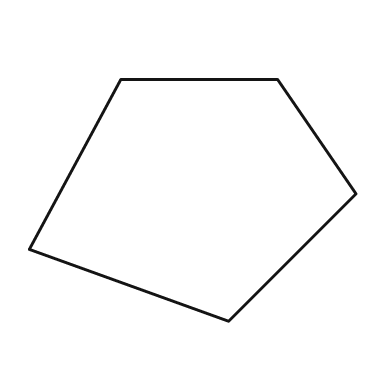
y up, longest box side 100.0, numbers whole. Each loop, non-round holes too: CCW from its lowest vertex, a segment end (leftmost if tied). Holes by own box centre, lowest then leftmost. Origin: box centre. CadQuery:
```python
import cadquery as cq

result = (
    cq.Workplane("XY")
    .moveTo(11.0, -37.0)
    .lineTo(50.0, 2.0)
    .lineTo(26.0, 37.0)
    .lineTo(-22.0, 37.0)
    .lineTo(-50.0, -15.0)
    .close()
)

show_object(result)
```